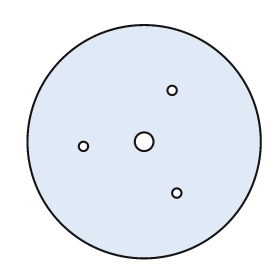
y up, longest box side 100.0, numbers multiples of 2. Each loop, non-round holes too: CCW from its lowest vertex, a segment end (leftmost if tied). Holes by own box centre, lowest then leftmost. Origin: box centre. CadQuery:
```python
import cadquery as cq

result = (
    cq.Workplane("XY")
    .moveTo(0.0, 0.0)
    .circle(50.0)
    .moveTo(14.0, -22.0)
    .circle(2.0)
    .moveTo(-26.0, -2.0)
    .circle(2.0)
    .moveTo(0.0, 0.0)
    .circle(4.0)
    .moveTo(12.0, 22.0)
    .circle(2.0)
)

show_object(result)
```